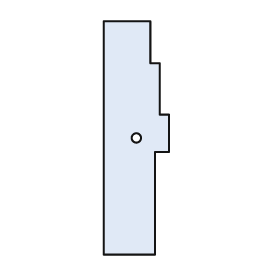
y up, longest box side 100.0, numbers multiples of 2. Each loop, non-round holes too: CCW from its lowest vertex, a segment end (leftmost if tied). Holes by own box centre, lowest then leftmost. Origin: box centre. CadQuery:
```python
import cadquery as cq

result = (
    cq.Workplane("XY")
    .moveTo(-14.0, -50.0)
    .lineTo(8.0, -50.0)
    .lineTo(8.0, -6.0)
    .lineTo(14.0, -6.0)
    .lineTo(14.0, 10.0)
    .lineTo(10.0, 10.0)
    .lineTo(10.0, 32.0)
    .lineTo(6.0, 32.0)
    .lineTo(6.0, 50.0)
    .lineTo(-14.0, 50.0)
    .close()
    .moveTo(0.0, 0.0)
    .circle(2.0)
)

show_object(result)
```